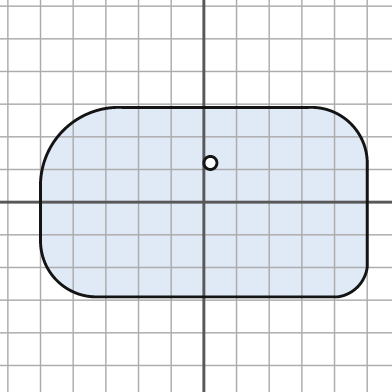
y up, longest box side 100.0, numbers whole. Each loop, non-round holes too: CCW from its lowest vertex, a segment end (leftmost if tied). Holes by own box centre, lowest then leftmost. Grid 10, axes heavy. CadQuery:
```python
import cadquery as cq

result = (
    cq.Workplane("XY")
    .moveTo(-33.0, -29.0)
    .lineTo(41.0, -29.0)
    .threePointArc((47.0, -26.0), (50.0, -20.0))
    .lineTo(50.0, 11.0)
    .threePointArc((45.0, 24.0), (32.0, 29.0))
    .lineTo(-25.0, 29.0)
    .threePointArc((-43.0, 22.0), (-50.0, 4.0))
    .lineTo(-50.0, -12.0)
    .threePointArc((-45.0, -24.0), (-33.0, -29.0))
    .close()
    .moveTo(2.0, 12.0)
    .circle(2.0)
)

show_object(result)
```